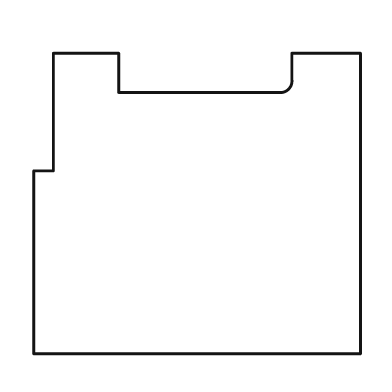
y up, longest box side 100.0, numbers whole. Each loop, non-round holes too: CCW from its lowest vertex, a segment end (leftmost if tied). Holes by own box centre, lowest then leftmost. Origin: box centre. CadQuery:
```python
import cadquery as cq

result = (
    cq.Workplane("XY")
    .moveTo(-50.0, -46.0)
    .lineTo(50.0, -46.0)
    .lineTo(50.0, 46.0)
    .lineTo(29.0, 46.0)
    .lineTo(29.0, 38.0)
    .threePointArc((28.0, 35.0), (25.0, 34.0))
    .lineTo(-24.0, 34.0)
    .lineTo(-24.0, 46.0)
    .lineTo(-44.0, 46.0)
    .lineTo(-44.0, 10.0)
    .lineTo(-50.0, 10.0)
    .close()
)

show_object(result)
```